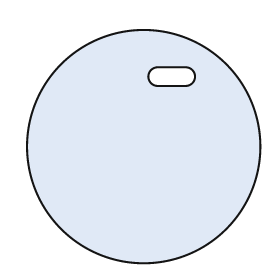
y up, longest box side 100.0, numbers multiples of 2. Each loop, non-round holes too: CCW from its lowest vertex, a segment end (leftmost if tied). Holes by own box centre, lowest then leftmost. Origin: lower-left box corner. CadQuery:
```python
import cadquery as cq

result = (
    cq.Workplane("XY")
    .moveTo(50.0, 50.0)
    .circle(50.0)
    .moveTo(56.0, 76.0)
    .lineTo(68.0, 76.0)
    .threePointArc((72.0, 80.0), (68.0, 84.0))
    .lineTo(56.0, 84.0)
    .threePointArc((52.0, 80.0), (56.0, 76.0))
    .close()
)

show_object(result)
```